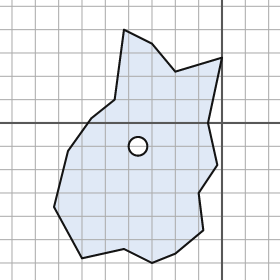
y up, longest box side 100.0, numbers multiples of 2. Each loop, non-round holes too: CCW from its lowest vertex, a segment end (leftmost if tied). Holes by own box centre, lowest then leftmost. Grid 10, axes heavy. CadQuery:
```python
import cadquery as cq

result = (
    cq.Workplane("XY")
    .moveTo(-30.0, -60.0)
    .lineTo(-20.0, -56.0)
    .lineTo(-8.0, -46.0)
    .lineTo(-10.0, -30.0)
    .lineTo(-2.0, -18.0)
    .lineTo(-6.0, 0.0)
    .lineTo(0.0, 28.0)
    .lineTo(-20.0, 22.0)
    .lineTo(-30.0, 34.0)
    .lineTo(-42.0, 40.0)
    .lineTo(-46.0, 10.0)
    .lineTo(-56.0, 2.0)
    .lineTo(-66.0, -12.0)
    .lineTo(-72.0, -36.0)
    .lineTo(-60.0, -58.0)
    .lineTo(-42.0, -54.0)
    .close()
    .moveTo(-36.0, -10.0)
    .circle(4.0)
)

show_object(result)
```